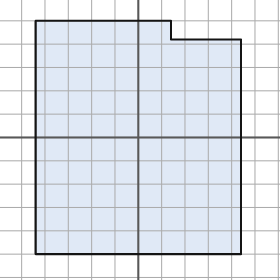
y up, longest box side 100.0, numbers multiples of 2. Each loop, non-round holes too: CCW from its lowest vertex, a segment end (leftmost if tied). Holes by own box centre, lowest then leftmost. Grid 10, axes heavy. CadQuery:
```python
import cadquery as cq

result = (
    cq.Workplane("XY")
    .moveTo(-44.0, -50.0)
    .lineTo(44.0, -50.0)
    .lineTo(44.0, 42.0)
    .lineTo(14.0, 42.0)
    .lineTo(14.0, 50.0)
    .lineTo(-44.0, 50.0)
    .close()
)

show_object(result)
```